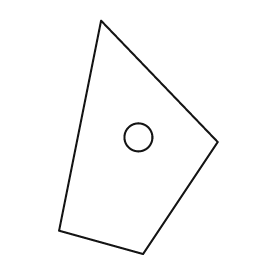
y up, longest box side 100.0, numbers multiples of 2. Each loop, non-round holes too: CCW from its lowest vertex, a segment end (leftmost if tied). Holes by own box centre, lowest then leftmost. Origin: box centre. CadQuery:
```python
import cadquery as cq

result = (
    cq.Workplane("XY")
    .moveTo(2.0, -50.0)
    .lineTo(34.0, -2.0)
    .lineTo(-16.0, 50.0)
    .lineTo(-34.0, -40.0)
    .close()
    .moveTo(0.0, 0.0)
    .circle(6.0)
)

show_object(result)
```